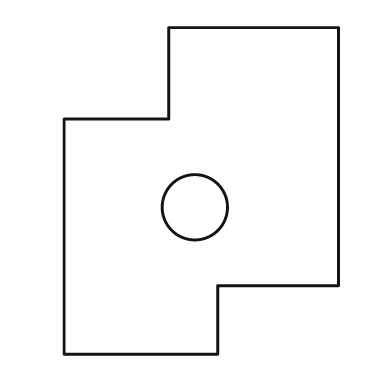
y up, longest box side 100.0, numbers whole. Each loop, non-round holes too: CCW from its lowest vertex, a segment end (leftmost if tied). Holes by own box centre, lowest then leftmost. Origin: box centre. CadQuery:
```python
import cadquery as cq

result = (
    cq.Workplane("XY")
    .moveTo(-42.0, -50.0)
    .lineTo(5.0, -50.0)
    .lineTo(5.0, -29.0)
    .lineTo(42.0, -29.0)
    .lineTo(42.0, 50.0)
    .lineTo(-10.0, 50.0)
    .lineTo(-10.0, 22.0)
    .lineTo(-42.0, 22.0)
    .close()
    .moveTo(-2.0, -5.0)
    .circle(10.0)
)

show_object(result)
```